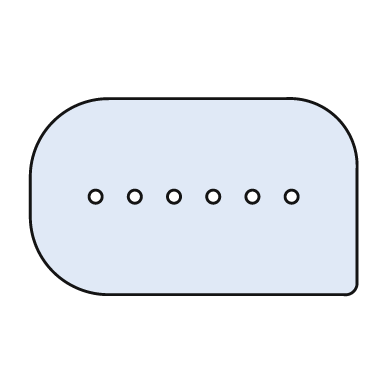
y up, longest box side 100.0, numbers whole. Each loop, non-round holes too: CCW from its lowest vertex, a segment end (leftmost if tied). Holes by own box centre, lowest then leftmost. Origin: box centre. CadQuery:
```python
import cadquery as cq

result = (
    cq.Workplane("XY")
    .moveTo(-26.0, -30.0)
    .lineTo(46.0, -30.0)
    .threePointArc((49.0, -29.0), (50.0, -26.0))
    .lineTo(50.0, 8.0)
    .threePointArc((44.0, 24.0), (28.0, 30.0))
    .lineTo(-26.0, 30.0)
    .threePointArc((-43.0, 23.0), (-50.0, 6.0))
    .lineTo(-50.0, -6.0)
    .threePointArc((-43.0, -23.0), (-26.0, -30.0))
    .close()
    .moveTo(-30.0, 0.0)
    .circle(2.0)
    .moveTo(-18.0, 0.0)
    .circle(2.0)
    .moveTo(-6.0, 0.0)
    .circle(2.0)
    .moveTo(6.0, 0.0)
    .circle(2.0)
    .moveTo(18.0, 0.0)
    .circle(2.0)
    .moveTo(30.0, 0.0)
    .circle(2.0)
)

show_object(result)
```